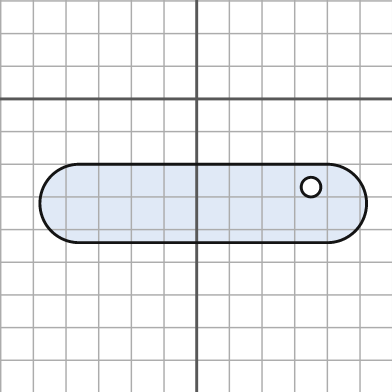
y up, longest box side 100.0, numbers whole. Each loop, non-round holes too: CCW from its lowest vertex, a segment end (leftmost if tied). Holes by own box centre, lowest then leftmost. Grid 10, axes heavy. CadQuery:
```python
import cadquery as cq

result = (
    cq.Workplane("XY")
    .moveTo(-36.0, -44.0)
    .lineTo(40.0, -44.0)
    .threePointArc((52.0, -32.0), (40.0, -20.0))
    .lineTo(-36.0, -20.0)
    .threePointArc((-48.0, -32.0), (-36.0, -44.0))
    .close()
    .moveTo(35.0, -27.0)
    .circle(3.0)
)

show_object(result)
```